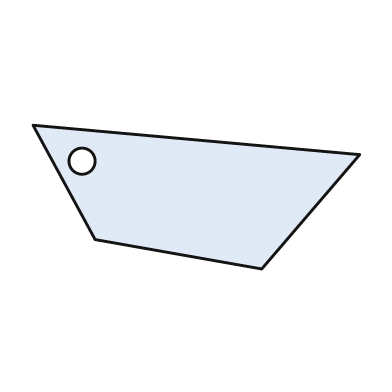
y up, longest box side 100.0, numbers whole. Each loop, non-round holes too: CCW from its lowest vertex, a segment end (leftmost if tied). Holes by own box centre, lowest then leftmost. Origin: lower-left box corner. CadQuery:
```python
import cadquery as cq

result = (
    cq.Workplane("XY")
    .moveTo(70.0, 0.0)
    .lineTo(100.0, 35.0)
    .lineTo(0.0, 44.0)
    .lineTo(19.0, 9.0)
    .close()
    .moveTo(15.0, 33.0)
    .circle(4.0)
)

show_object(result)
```